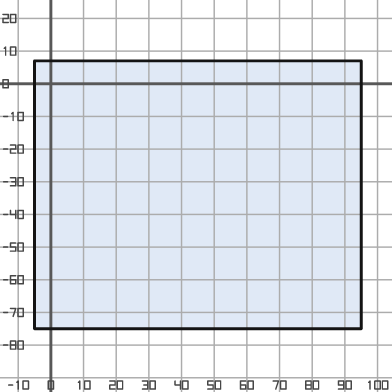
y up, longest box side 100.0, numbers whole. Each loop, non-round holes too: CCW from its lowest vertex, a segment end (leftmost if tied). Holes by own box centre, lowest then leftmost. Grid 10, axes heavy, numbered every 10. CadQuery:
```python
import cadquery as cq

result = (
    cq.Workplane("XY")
    .moveTo(-5.0, -75.0)
    .lineTo(95.0, -75.0)
    .lineTo(95.0, 7.0)
    .lineTo(-5.0, 7.0)
    .close()
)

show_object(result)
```